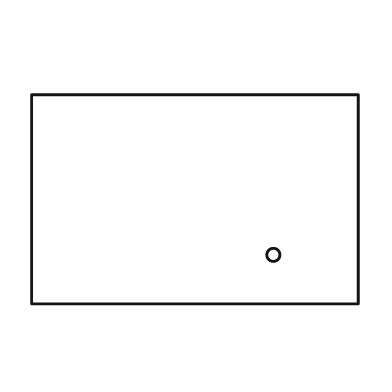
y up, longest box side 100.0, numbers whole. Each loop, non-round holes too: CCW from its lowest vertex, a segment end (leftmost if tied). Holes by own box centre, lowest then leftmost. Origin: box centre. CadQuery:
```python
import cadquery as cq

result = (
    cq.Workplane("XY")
    .moveTo(-50.0, -32.0)
    .lineTo(50.0, -32.0)
    .lineTo(50.0, 32.0)
    .lineTo(-50.0, 32.0)
    .close()
    .moveTo(24.0, -17.0)
    .circle(2.0)
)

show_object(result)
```